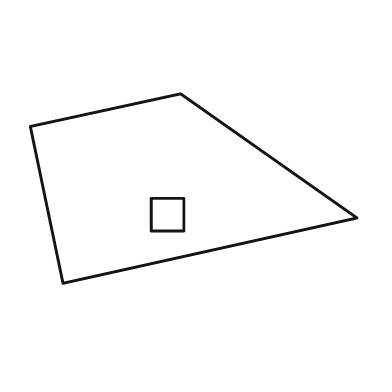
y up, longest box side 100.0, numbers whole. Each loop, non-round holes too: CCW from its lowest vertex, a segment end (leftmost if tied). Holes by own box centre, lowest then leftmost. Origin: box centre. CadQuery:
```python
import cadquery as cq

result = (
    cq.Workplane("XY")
    .moveTo(-40.0, -29.0)
    .lineTo(50.0, -9.0)
    .lineTo(-4.0, 29.0)
    .lineTo(-50.0, 19.0)
    .close()
    .moveTo(-13.0, -13.0)
    .lineTo(-3.0, -13.0)
    .lineTo(-3.0, -3.0)
    .lineTo(-13.0, -3.0)
    .close()
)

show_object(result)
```